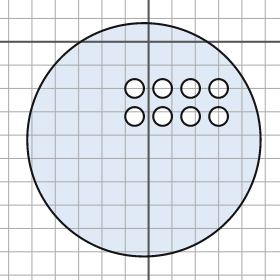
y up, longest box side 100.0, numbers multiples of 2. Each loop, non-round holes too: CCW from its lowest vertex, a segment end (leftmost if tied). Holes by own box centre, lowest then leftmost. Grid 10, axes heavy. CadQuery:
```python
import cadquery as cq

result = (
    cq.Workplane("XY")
    .moveTo(-2.0, -42.0)
    .circle(50.0)
    .moveTo(-6.0, -32.0)
    .circle(4.0)
    .moveTo(6.0, -32.0)
    .circle(4.0)
    .moveTo(18.0, -32.0)
    .circle(4.0)
    .moveTo(30.0, -32.0)
    .circle(4.0)
    .moveTo(-6.0, -20.0)
    .circle(4.0)
    .moveTo(6.0, -20.0)
    .circle(4.0)
    .moveTo(18.0, -20.0)
    .circle(4.0)
    .moveTo(30.0, -20.0)
    .circle(4.0)
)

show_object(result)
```